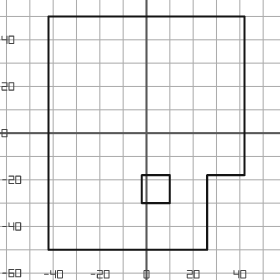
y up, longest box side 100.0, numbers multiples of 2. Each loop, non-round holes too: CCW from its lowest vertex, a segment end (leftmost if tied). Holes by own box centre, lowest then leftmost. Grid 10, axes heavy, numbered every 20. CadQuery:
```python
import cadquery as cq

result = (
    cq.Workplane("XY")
    .moveTo(-42.0, -50.0)
    .lineTo(26.0, -50.0)
    .lineTo(26.0, -18.0)
    .lineTo(42.0, -18.0)
    .lineTo(42.0, 50.0)
    .lineTo(-42.0, 50.0)
    .close()
    .moveTo(-2.0, -30.0)
    .lineTo(10.0, -30.0)
    .lineTo(10.0, -18.0)
    .lineTo(-2.0, -18.0)
    .close()
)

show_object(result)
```